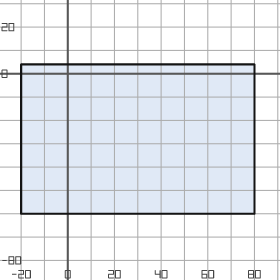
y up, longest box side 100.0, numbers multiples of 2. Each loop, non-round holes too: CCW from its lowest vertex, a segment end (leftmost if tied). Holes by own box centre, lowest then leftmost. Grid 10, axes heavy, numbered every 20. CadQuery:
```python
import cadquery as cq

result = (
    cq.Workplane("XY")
    .moveTo(-20.0, -60.0)
    .lineTo(80.0, -60.0)
    .lineTo(80.0, 4.0)
    .lineTo(-20.0, 4.0)
    .close()
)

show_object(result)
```